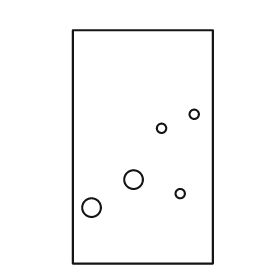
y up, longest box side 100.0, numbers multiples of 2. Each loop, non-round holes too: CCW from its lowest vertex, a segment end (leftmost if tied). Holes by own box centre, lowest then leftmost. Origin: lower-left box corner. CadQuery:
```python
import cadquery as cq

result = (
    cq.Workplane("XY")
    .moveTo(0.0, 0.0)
    .lineTo(60.0, 0.0)
    .lineTo(60.0, 100.0)
    .lineTo(0.0, 100.0)
    .close()
    .moveTo(8.0, 24.0)
    .circle(4.0)
    .moveTo(46.0, 30.0)
    .circle(2.0)
    .moveTo(26.0, 36.0)
    .circle(4.0)
    .moveTo(38.0, 58.0)
    .circle(2.0)
    .moveTo(52.0, 64.0)
    .circle(2.0)
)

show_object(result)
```